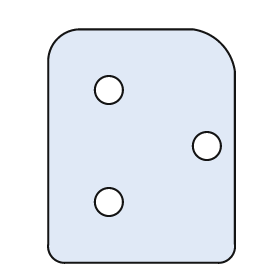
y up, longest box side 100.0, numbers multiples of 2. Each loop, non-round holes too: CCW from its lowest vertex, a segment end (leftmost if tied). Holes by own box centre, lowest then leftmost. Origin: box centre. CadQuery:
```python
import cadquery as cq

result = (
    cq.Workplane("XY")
    .moveTo(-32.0, -50.0)
    .lineTo(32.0, -50.0)
    .threePointArc((38.0, -48.0), (40.0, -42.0))
    .lineTo(40.0, 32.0)
    .threePointArc((34.0, 44.0), (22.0, 50.0))
    .lineTo(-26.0, 50.0)
    .threePointArc((-36.0, 46.0), (-40.0, 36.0))
    .lineTo(-40.0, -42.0)
    .threePointArc((-38.0, -48.0), (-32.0, -50.0))
    .close()
    .moveTo(-14.0, -24.0)
    .circle(6.0)
    .moveTo(28.0, 0.0)
    .circle(6.0)
    .moveTo(-14.0, 24.0)
    .circle(6.0)
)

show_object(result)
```